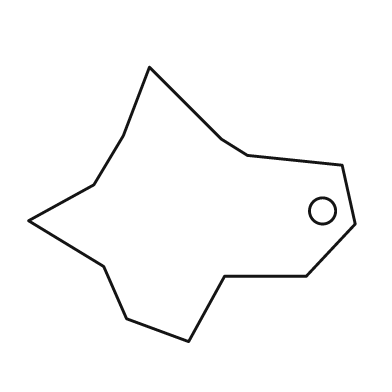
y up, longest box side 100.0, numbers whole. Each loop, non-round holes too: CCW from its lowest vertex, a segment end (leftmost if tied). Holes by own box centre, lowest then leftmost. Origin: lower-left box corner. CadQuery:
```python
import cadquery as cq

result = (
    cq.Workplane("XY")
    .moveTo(49.0, 0.0)
    .lineTo(60.0, 20.0)
    .lineTo(85.0, 20.0)
    .lineTo(100.0, 36.0)
    .lineTo(96.0, 54.0)
    .lineTo(67.0, 57.0)
    .lineTo(59.0, 62.0)
    .lineTo(37.0, 84.0)
    .lineTo(29.0, 63.0)
    .lineTo(20.0, 48.0)
    .lineTo(0.0, 37.0)
    .lineTo(23.0, 23.0)
    .lineTo(30.0, 7.0)
    .close()
    .moveTo(90.0, 40.0)
    .circle(4.0)
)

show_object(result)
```